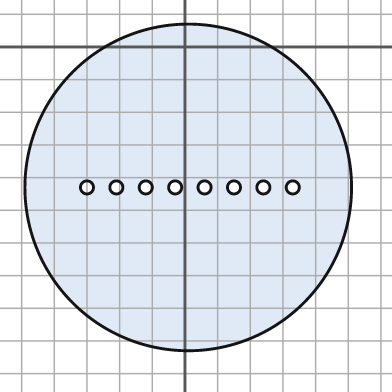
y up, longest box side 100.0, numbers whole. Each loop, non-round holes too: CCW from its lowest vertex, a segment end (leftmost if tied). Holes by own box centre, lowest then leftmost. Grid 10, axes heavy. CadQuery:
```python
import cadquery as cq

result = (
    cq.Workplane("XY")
    .moveTo(1.0, -43.0)
    .circle(50.0)
    .moveTo(-30.0, -43.0)
    .circle(2.0)
    .moveTo(-21.0, -43.0)
    .circle(2.0)
    .moveTo(-12.0, -43.0)
    .circle(2.0)
    .moveTo(-3.0, -43.0)
    .circle(2.0)
    .moveTo(6.0, -43.0)
    .circle(2.0)
    .moveTo(15.0, -43.0)
    .circle(2.0)
    .moveTo(24.0, -43.0)
    .circle(2.0)
    .moveTo(33.0, -43.0)
    .circle(2.0)
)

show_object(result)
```